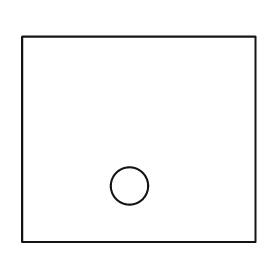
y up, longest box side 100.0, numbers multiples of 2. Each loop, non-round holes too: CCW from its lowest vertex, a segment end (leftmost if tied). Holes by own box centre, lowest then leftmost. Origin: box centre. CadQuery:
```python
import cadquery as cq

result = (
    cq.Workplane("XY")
    .moveTo(-50.0, -44.0)
    .lineTo(50.0, -44.0)
    .lineTo(50.0, 44.0)
    .lineTo(-50.0, 44.0)
    .close()
    .moveTo(-4.0, -20.0)
    .circle(8.0)
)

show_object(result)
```